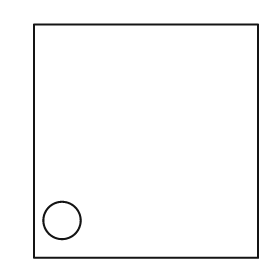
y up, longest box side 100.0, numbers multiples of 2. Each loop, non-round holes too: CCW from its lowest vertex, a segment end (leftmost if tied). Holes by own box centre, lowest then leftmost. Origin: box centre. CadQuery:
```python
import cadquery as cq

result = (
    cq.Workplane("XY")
    .moveTo(-48.0, -50.0)
    .lineTo(48.0, -50.0)
    .lineTo(48.0, 50.0)
    .lineTo(-48.0, 50.0)
    .close()
    .moveTo(-36.0, -34.0)
    .circle(8.0)
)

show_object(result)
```